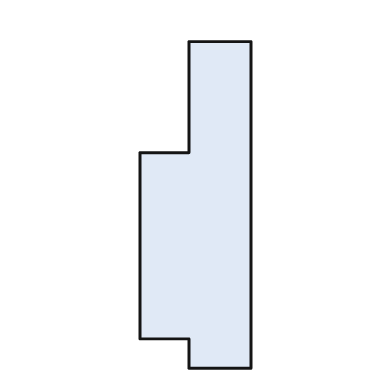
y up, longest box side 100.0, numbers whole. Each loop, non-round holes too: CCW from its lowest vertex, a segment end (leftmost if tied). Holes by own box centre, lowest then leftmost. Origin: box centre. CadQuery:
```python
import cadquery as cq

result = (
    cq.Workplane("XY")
    .moveTo(-2.0, -50.0)
    .lineTo(17.0, -50.0)
    .lineTo(17.0, 50.0)
    .lineTo(-2.0, 50.0)
    .lineTo(-2.0, 16.0)
    .lineTo(-17.0, 16.0)
    .lineTo(-17.0, -41.0)
    .lineTo(-2.0, -41.0)
    .close()
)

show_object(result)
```